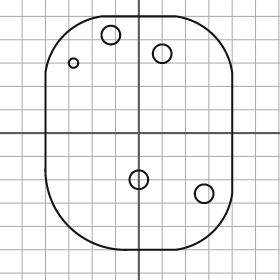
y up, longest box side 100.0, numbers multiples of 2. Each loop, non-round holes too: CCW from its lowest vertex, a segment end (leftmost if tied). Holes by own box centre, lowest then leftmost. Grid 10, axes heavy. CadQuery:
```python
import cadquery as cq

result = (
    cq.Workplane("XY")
    .moveTo(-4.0, -50.0)
    .lineTo(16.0, -50.0)
    .threePointArc((32.0, -42.0), (40.0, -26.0))
    .lineTo(40.0, 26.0)
    .threePointArc((32.0, 42.0), (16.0, 50.0))
    .lineTo(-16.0, 50.0)
    .threePointArc((-32.0, 42.0), (-40.0, 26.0))
    .lineTo(-40.0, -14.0)
    .threePointArc((-30.0, -40.0), (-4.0, -50.0))
    .close()
    .moveTo(28.0, -26.0)
    .circle(4.0)
    .moveTo(0.0, -20.0)
    .circle(4.0)
    .moveTo(-28.0, 30.0)
    .circle(2.0)
    .moveTo(10.0, 34.0)
    .circle(4.0)
    .moveTo(-12.0, 42.0)
    .circle(4.0)
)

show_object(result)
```